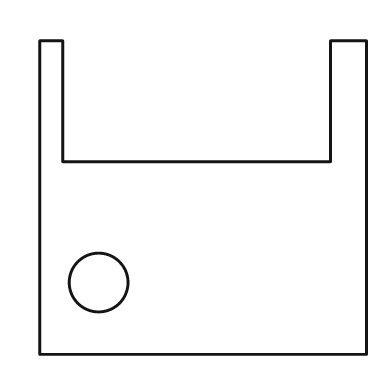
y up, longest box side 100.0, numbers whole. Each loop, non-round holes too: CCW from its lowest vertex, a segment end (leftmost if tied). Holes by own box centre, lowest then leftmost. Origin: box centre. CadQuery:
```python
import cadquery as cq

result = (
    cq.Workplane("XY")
    .moveTo(-50.0, -48.0)
    .lineTo(50.0, -48.0)
    .lineTo(50.0, 48.0)
    .lineTo(39.0, 48.0)
    .lineTo(39.0, 11.0)
    .lineTo(-43.0, 11.0)
    .lineTo(-43.0, 48.0)
    .lineTo(-50.0, 48.0)
    .close()
    .moveTo(-32.0, -26.0)
    .circle(9.0)
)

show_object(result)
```